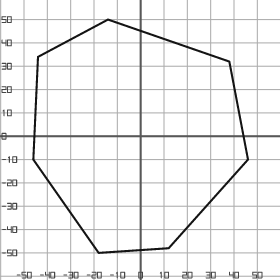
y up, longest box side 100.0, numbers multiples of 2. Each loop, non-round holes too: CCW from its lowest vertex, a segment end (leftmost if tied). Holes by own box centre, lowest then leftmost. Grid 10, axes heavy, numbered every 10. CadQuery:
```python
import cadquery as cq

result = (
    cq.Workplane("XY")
    .moveTo(-18.0, -50.0)
    .lineTo(12.0, -48.0)
    .lineTo(46.0, -10.0)
    .lineTo(38.0, 32.0)
    .lineTo(-14.0, 50.0)
    .lineTo(-44.0, 34.0)
    .lineTo(-46.0, -10.0)
    .close()
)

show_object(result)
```